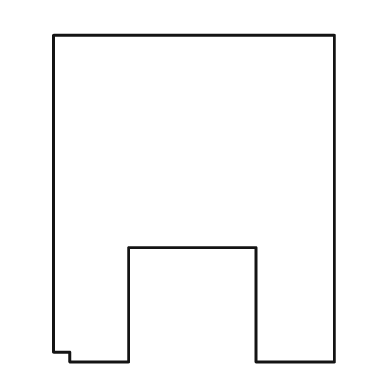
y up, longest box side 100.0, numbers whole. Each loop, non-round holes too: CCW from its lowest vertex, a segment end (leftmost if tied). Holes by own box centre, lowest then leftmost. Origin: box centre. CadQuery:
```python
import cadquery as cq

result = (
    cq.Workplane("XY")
    .moveTo(-38.0, -50.0)
    .lineTo(-20.0, -50.0)
    .lineTo(-20.0, -15.0)
    .lineTo(19.0, -15.0)
    .lineTo(19.0, -50.0)
    .lineTo(43.0, -50.0)
    .lineTo(43.0, 50.0)
    .lineTo(-43.0, 50.0)
    .lineTo(-43.0, -47.0)
    .lineTo(-38.0, -47.0)
    .close()
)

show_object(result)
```